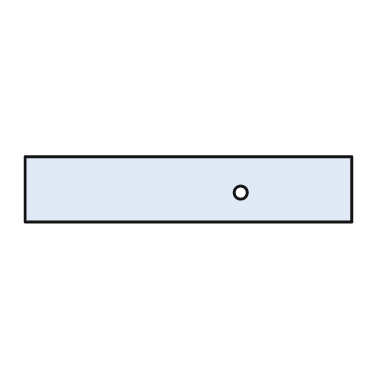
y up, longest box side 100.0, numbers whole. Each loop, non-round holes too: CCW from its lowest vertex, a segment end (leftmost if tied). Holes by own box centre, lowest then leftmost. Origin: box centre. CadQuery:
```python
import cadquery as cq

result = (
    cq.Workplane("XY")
    .moveTo(-50.0, -10.0)
    .lineTo(50.0, -10.0)
    .lineTo(50.0, 10.0)
    .lineTo(-50.0, 10.0)
    .close()
    .moveTo(16.0, -1.0)
    .circle(2.0)
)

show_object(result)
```